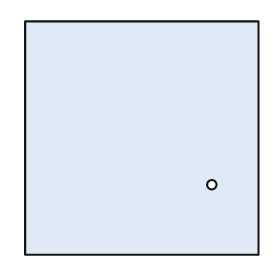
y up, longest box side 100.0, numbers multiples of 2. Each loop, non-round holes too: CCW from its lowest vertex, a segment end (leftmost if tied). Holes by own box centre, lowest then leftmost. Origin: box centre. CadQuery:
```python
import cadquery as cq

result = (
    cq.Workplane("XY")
    .moveTo(-50.0, -50.0)
    .lineTo(50.0, -50.0)
    .lineTo(50.0, 50.0)
    .lineTo(-50.0, 50.0)
    .close()
    .moveTo(30.0, -20.0)
    .circle(2.0)
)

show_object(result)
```